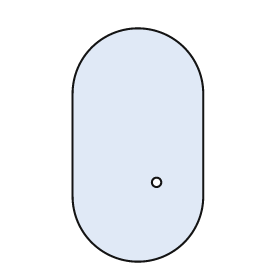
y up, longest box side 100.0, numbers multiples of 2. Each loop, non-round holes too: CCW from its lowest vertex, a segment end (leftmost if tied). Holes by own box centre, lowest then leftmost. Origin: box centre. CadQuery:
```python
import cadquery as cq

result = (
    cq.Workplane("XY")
    .moveTo(-28.0, -22.0)
    .threePointArc((0.0, -50.0), (28.0, -22.0))
    .lineTo(28.0, 22.0)
    .threePointArc((0.0, 50.0), (-28.0, 22.0))
    .close()
    .moveTo(8.0, -16.0)
    .circle(2.0)
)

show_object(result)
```